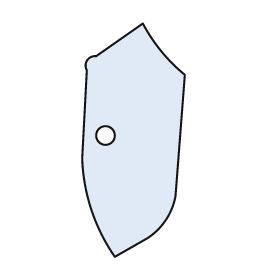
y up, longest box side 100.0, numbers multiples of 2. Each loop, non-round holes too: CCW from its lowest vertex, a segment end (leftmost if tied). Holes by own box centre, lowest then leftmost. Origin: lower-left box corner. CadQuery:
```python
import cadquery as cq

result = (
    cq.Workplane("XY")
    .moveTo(14.0, 0.0)
    .lineTo(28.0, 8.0)
    .threePointArc((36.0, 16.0), (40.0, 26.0))
    .lineTo(44.0, 78.0)
    .threePointArc((34.0, 88.0), (26.0, 100.0))
    .lineTo(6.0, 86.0)
    .threePointArc((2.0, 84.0), (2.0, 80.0))
    .lineTo(0.0, 42.0)
    .threePointArc((4.0, 20.0), (14.0, 0.0))
    .close()
    .moveTo(10.0, 52.0)
    .circle(4.0)
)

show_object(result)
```